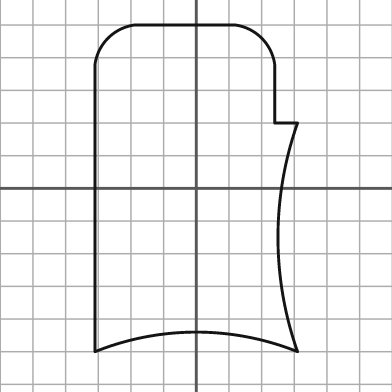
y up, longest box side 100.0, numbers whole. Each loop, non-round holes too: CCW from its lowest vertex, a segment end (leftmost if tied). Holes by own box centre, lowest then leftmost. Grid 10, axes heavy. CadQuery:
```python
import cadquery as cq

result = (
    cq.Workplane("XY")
    .moveTo(-31.0, -50.0)
    .threePointArc((0.0, -44.0), (31.0, -50.0))
    .threePointArc((25.0, -15.0), (31.0, 20.0))
    .lineTo(24.0, 20.0)
    .lineTo(24.0, 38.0)
    .threePointArc((20.0, 46.0), (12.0, 50.0))
    .lineTo(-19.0, 50.0)
    .threePointArc((-27.0, 46.0), (-31.0, 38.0))
    .close()
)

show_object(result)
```